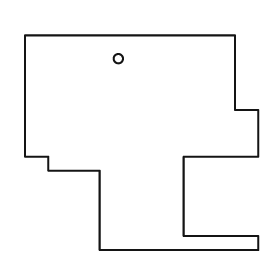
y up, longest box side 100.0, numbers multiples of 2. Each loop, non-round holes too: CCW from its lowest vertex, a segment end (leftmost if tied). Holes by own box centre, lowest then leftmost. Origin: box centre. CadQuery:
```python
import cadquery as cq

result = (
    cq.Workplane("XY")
    .moveTo(-18.0, -46.0)
    .lineTo(50.0, -46.0)
    .lineTo(50.0, -40.0)
    .lineTo(18.0, -40.0)
    .lineTo(18.0, -6.0)
    .lineTo(50.0, -6.0)
    .lineTo(50.0, 14.0)
    .lineTo(40.0, 14.0)
    .lineTo(40.0, 46.0)
    .lineTo(-50.0, 46.0)
    .lineTo(-50.0, -6.0)
    .lineTo(-40.0, -6.0)
    .lineTo(-40.0, -12.0)
    .lineTo(-18.0, -12.0)
    .close()
    .moveTo(-10.0, 36.0)
    .circle(2.0)
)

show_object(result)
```